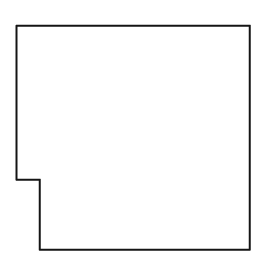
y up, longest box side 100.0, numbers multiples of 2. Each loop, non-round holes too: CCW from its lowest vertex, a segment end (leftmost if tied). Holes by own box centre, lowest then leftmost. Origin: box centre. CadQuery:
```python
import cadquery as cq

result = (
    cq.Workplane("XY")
    .moveTo(-40.0, -48.0)
    .lineTo(50.0, -48.0)
    .lineTo(50.0, 48.0)
    .lineTo(-50.0, 48.0)
    .lineTo(-50.0, -18.0)
    .lineTo(-40.0, -18.0)
    .close()
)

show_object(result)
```